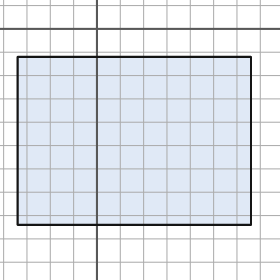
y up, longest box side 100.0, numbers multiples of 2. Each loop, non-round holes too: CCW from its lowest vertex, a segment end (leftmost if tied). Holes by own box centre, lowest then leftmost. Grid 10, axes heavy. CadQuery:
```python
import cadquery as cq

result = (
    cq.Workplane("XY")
    .moveTo(-34.0, -84.0)
    .lineTo(66.0, -84.0)
    .lineTo(66.0, -12.0)
    .lineTo(-34.0, -12.0)
    .close()
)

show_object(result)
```